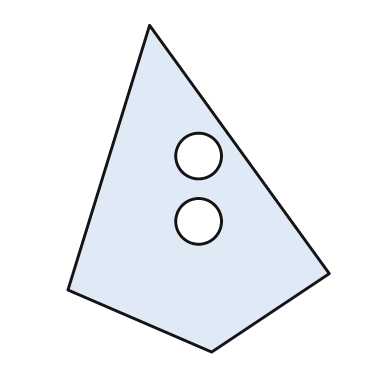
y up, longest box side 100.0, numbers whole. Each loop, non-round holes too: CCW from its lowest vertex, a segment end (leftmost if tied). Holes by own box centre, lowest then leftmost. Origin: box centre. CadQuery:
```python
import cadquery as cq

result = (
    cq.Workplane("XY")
    .moveTo(4.0, -50.0)
    .lineTo(40.0, -26.0)
    .lineTo(-15.0, 50.0)
    .lineTo(-40.0, -31.0)
    .close()
    .moveTo(0.0, -10.0)
    .circle(7.0)
    .moveTo(0.0, 10.0)
    .circle(7.0)
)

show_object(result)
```